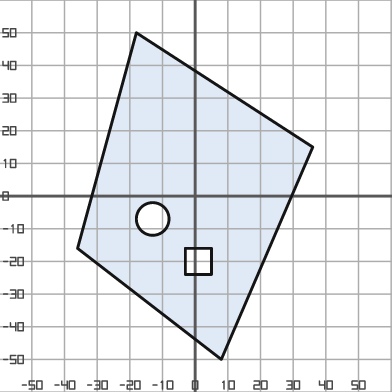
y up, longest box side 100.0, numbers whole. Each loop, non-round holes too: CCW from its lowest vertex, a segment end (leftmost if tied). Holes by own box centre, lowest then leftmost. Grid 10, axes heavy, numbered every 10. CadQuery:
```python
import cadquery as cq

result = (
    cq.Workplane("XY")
    .moveTo(8.0, -50.0)
    .lineTo(36.0, 15.0)
    .lineTo(-18.0, 50.0)
    .lineTo(-36.0, -16.0)
    .close()
    .moveTo(-3.0, -24.0)
    .lineTo(5.0, -24.0)
    .lineTo(5.0, -16.0)
    .lineTo(-3.0, -16.0)
    .close()
    .moveTo(-13.0, -7.0)
    .circle(5.0)
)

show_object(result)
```